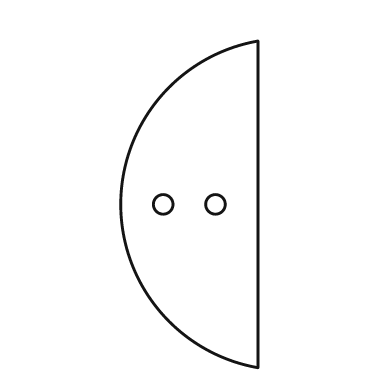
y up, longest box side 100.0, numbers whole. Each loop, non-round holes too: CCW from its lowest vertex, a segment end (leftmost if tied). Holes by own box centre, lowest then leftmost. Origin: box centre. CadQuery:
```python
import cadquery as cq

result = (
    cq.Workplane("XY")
    .moveTo(21.0, -50.0)
    .lineTo(21.0, 50.0)
    .threePointArc((-21.0, 0.0), (21.0, -50.0))
    .close()
    .moveTo(-8.0, 0.0)
    .circle(3.0)
    .moveTo(8.0, 0.0)
    .circle(3.0)
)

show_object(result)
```